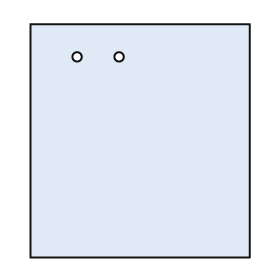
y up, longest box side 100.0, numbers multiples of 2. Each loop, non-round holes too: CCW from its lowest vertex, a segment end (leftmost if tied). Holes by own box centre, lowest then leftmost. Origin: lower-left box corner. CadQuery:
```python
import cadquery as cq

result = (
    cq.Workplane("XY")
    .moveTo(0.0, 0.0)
    .lineTo(94.0, 0.0)
    .lineTo(94.0, 100.0)
    .lineTo(0.0, 100.0)
    .close()
    .moveTo(20.0, 86.0)
    .circle(2.0)
    .moveTo(38.0, 86.0)
    .circle(2.0)
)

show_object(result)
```